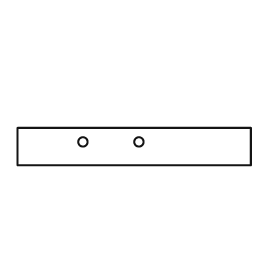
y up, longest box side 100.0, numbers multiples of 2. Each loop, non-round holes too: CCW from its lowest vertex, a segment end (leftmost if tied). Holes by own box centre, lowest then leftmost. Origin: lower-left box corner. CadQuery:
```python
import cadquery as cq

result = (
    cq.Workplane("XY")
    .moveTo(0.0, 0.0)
    .lineTo(100.0, 0.0)
    .lineTo(100.0, 16.0)
    .lineTo(0.0, 16.0)
    .close()
    .moveTo(28.0, 10.0)
    .circle(2.0)
    .moveTo(52.0, 10.0)
    .circle(2.0)
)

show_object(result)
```